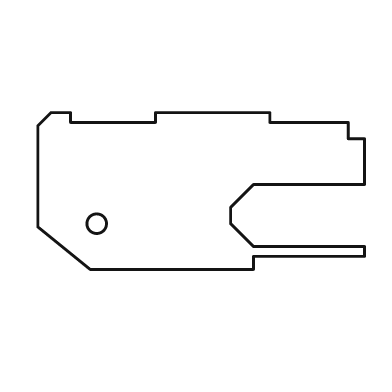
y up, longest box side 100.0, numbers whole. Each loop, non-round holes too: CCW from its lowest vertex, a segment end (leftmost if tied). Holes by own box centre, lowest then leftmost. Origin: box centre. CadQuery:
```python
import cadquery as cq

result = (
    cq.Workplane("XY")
    .moveTo(-34.0, -24.0)
    .lineTo(16.0, -24.0)
    .lineTo(16.0, -20.0)
    .lineTo(50.0, -20.0)
    .lineTo(50.0, -17.0)
    .lineTo(16.0, -17.0)
    .lineTo(9.0, -10.0)
    .lineTo(9.0, -5.0)
    .lineTo(16.0, 2.0)
    .lineTo(50.0, 2.0)
    .lineTo(50.0, 16.0)
    .lineTo(45.0, 16.0)
    .lineTo(45.0, 21.0)
    .lineTo(21.0, 21.0)
    .lineTo(21.0, 24.0)
    .lineTo(-14.0, 24.0)
    .lineTo(-14.0, 21.0)
    .lineTo(-40.0, 21.0)
    .lineTo(-40.0, 24.0)
    .lineTo(-46.0, 24.0)
    .lineTo(-50.0, 20.0)
    .lineTo(-50.0, -11.0)
    .close()
    .moveTo(-32.0, -10.0)
    .circle(3.0)
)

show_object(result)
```